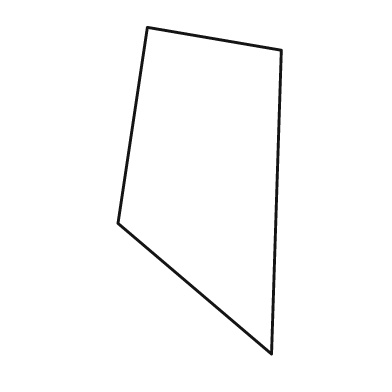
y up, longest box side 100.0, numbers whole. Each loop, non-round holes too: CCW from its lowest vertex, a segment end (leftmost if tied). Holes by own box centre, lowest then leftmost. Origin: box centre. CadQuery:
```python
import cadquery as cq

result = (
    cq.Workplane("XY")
    .moveTo(22.0, -50.0)
    .lineTo(25.0, 43.0)
    .lineTo(-16.0, 50.0)
    .lineTo(-25.0, -10.0)
    .close()
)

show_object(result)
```